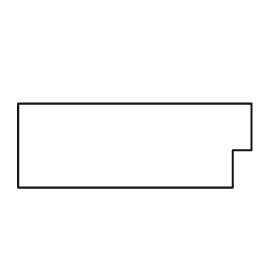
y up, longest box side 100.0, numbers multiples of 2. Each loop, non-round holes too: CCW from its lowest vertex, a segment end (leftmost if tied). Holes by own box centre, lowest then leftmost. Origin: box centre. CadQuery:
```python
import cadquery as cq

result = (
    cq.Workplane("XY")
    .moveTo(-50.0, -18.0)
    .lineTo(42.0, -18.0)
    .lineTo(42.0, -2.0)
    .lineTo(50.0, -2.0)
    .lineTo(50.0, 18.0)
    .lineTo(-50.0, 18.0)
    .close()
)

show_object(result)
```